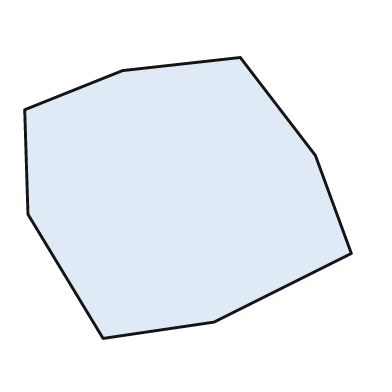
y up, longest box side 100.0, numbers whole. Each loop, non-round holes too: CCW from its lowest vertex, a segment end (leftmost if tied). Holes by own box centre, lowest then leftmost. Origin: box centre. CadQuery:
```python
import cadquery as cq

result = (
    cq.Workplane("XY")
    .moveTo(-26.0, -43.0)
    .lineTo(8.0, -38.0)
    .lineTo(50.0, -17.0)
    .lineTo(39.0, 13.0)
    .lineTo(16.0, 43.0)
    .lineTo(-20.0, 39.0)
    .lineTo(-50.0, 27.0)
    .lineTo(-49.0, -5.0)
    .close()
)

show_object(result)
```